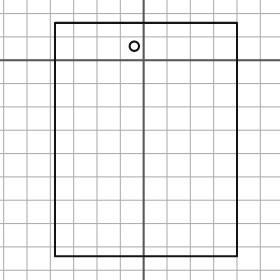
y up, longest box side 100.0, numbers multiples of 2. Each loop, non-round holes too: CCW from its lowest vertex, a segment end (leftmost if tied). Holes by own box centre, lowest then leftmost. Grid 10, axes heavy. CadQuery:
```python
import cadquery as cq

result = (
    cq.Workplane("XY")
    .moveTo(-38.0, -84.0)
    .lineTo(40.0, -84.0)
    .lineTo(40.0, 16.0)
    .lineTo(-38.0, 16.0)
    .close()
    .moveTo(-4.0, 6.0)
    .circle(2.0)
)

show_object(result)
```